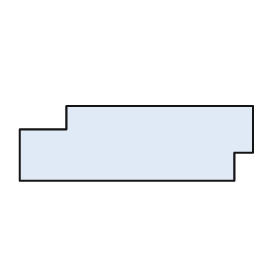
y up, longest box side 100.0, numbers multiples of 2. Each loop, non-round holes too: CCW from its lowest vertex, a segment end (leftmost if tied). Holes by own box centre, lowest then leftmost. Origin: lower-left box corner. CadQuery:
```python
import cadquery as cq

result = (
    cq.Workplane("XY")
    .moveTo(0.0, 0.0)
    .lineTo(92.0, 0.0)
    .lineTo(92.0, 12.0)
    .lineTo(100.0, 12.0)
    .lineTo(100.0, 32.0)
    .lineTo(20.0, 32.0)
    .lineTo(20.0, 22.0)
    .lineTo(0.0, 22.0)
    .close()
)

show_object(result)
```